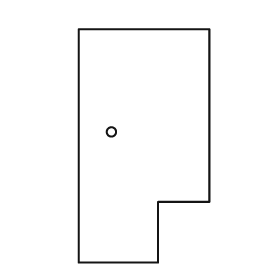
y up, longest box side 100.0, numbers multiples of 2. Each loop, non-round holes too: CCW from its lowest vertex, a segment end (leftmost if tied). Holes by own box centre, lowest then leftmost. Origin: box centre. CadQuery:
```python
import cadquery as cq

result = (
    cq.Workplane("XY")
    .moveTo(-28.0, -50.0)
    .lineTo(6.0, -50.0)
    .lineTo(6.0, -24.0)
    .lineTo(28.0, -24.0)
    .lineTo(28.0, 50.0)
    .lineTo(-28.0, 50.0)
    .close()
    .moveTo(-14.0, 6.0)
    .circle(2.0)
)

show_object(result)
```